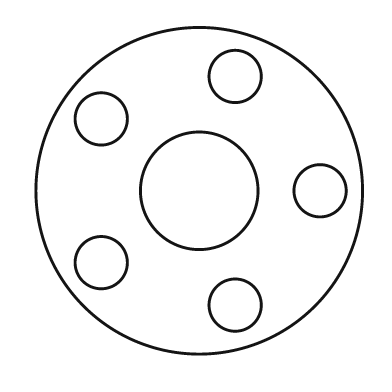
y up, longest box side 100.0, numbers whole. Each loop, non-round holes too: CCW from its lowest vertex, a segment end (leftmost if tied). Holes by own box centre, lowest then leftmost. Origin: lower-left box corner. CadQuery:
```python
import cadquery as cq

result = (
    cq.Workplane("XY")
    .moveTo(50.0, 50.0)
    .circle(50.0)
    .moveTo(61.0, 15.0)
    .circle(8.0)
    .moveTo(20.0, 28.0)
    .circle(8.0)
    .moveTo(50.0, 50.0)
    .circle(18.0)
    .moveTo(87.0, 50.0)
    .circle(8.0)
    .moveTo(20.0, 72.0)
    .circle(8.0)
    .moveTo(61.0, 85.0)
    .circle(8.0)
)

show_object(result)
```